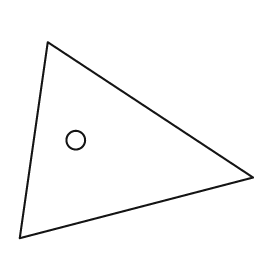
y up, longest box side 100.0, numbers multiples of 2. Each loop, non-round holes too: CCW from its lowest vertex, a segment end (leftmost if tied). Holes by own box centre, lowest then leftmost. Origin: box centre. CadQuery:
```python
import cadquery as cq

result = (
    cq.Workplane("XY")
    .moveTo(-50.0, -42.0)
    .lineTo(50.0, -16.0)
    .lineTo(-38.0, 42.0)
    .close()
    .moveTo(-26.0, 0.0)
    .circle(4.0)
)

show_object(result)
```